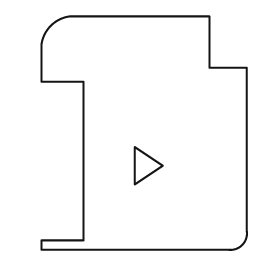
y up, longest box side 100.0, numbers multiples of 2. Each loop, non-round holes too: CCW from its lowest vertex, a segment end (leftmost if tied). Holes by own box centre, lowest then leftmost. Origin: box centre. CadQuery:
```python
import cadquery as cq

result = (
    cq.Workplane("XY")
    .moveTo(-44.0, -50.0)
    .lineTo(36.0, -50.0)
    .threePointArc((42.0, -48.0), (44.0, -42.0))
    .lineTo(44.0, 28.0)
    .lineTo(28.0, 28.0)
    .lineTo(28.0, 50.0)
    .lineTo(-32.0, 50.0)
    .threePointArc((-40.0, 46.0), (-44.0, 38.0))
    .lineTo(-44.0, 22.0)
    .lineTo(-26.0, 22.0)
    .lineTo(-26.0, -46.0)
    .lineTo(-44.0, -46.0)
    .close()
    .moveTo(-4.0, -22.0)
    .lineTo(8.0, -14.0)
    .lineTo(-4.0, -6.0)
    .close()
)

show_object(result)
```